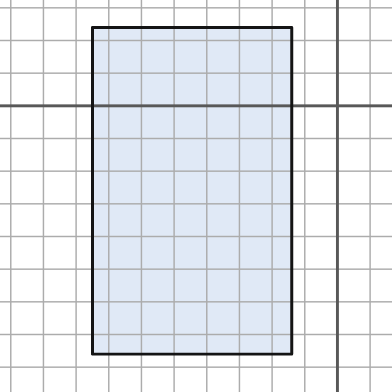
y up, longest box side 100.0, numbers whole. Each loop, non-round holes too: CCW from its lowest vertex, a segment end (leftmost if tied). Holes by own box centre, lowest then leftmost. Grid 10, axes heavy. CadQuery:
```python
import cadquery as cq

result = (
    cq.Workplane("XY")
    .moveTo(-75.0, -76.0)
    .lineTo(-14.0, -76.0)
    .lineTo(-14.0, 24.0)
    .lineTo(-75.0, 24.0)
    .close()
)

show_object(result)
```